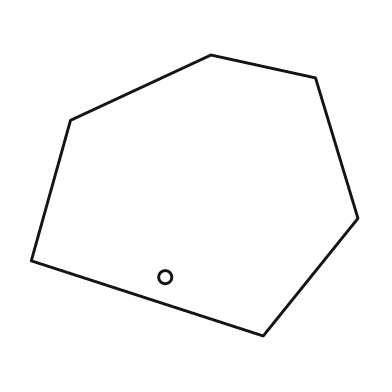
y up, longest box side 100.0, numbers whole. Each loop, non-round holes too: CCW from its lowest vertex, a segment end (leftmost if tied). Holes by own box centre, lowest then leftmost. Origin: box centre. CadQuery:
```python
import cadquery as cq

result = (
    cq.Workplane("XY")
    .moveTo(21.0, -43.0)
    .lineTo(50.0, -7.0)
    .lineTo(37.0, 36.0)
    .lineTo(5.0, 43.0)
    .lineTo(-38.0, 23.0)
    .lineTo(-50.0, -20.0)
    .close()
    .moveTo(-9.0, -25.0)
    .circle(2.0)
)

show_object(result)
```